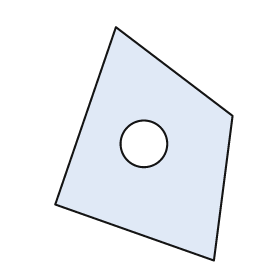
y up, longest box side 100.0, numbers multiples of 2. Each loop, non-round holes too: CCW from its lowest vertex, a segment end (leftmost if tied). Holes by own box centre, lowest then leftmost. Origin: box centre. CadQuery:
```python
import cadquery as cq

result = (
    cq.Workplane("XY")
    .moveTo(30.0, -50.0)
    .lineTo(38.0, 12.0)
    .lineTo(-12.0, 50.0)
    .lineTo(-38.0, -26.0)
    .close()
    .moveTo(0.0, 0.0)
    .circle(10.0)
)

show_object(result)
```